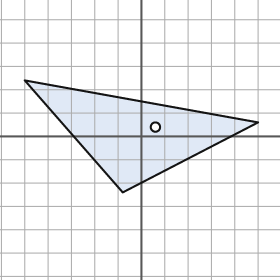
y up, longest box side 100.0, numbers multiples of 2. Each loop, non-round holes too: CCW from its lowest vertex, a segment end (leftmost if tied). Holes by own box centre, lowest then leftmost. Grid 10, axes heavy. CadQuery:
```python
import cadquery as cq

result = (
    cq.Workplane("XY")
    .moveTo(-8.0, -24.0)
    .lineTo(50.0, 6.0)
    .lineTo(-50.0, 24.0)
    .close()
    .moveTo(6.0, 4.0)
    .circle(2.0)
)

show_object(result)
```